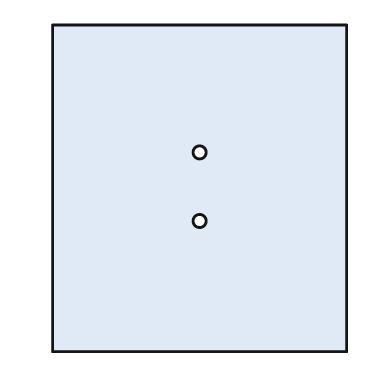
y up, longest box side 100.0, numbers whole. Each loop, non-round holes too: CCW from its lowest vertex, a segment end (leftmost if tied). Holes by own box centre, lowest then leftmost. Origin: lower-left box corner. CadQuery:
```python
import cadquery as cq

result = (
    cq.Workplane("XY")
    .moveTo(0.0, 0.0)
    .lineTo(90.0, 0.0)
    .lineTo(90.0, 100.0)
    .lineTo(0.0, 100.0)
    .close()
    .moveTo(45.0, 40.0)
    .circle(2.0)
    .moveTo(45.0, 61.0)
    .circle(2.0)
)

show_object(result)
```